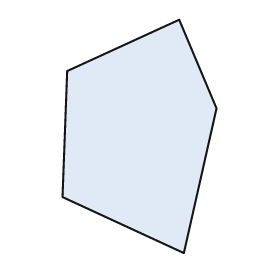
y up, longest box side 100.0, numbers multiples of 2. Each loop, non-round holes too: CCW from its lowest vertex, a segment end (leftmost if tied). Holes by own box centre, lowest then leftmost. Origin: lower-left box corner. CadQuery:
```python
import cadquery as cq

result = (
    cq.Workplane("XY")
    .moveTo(52.0, 0.0)
    .lineTo(66.0, 62.0)
    .lineTo(50.0, 100.0)
    .lineTo(2.0, 78.0)
    .lineTo(0.0, 24.0)
    .close()
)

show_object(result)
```